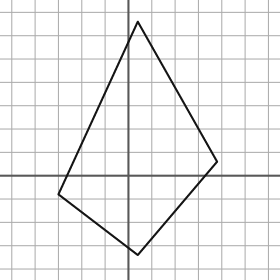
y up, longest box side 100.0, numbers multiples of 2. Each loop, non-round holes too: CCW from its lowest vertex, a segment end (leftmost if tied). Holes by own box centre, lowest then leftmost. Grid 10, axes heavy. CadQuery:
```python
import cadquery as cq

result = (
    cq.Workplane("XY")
    .moveTo(4.0, -34.0)
    .lineTo(38.0, 6.0)
    .lineTo(4.0, 66.0)
    .lineTo(-30.0, -8.0)
    .close()
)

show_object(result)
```